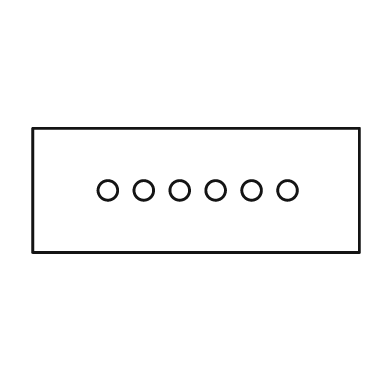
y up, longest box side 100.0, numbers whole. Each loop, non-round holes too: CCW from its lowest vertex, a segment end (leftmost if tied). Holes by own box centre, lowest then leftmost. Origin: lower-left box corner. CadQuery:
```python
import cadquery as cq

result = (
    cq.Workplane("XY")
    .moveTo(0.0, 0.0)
    .lineTo(100.0, 0.0)
    .lineTo(100.0, 38.0)
    .lineTo(0.0, 38.0)
    .close()
    .moveTo(23.0, 19.0)
    .circle(3.0)
    .moveTo(34.0, 19.0)
    .circle(3.0)
    .moveTo(45.0, 19.0)
    .circle(3.0)
    .moveTo(56.0, 19.0)
    .circle(3.0)
    .moveTo(67.0, 19.0)
    .circle(3.0)
    .moveTo(78.0, 19.0)
    .circle(3.0)
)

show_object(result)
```